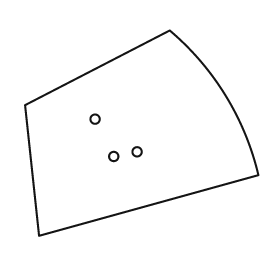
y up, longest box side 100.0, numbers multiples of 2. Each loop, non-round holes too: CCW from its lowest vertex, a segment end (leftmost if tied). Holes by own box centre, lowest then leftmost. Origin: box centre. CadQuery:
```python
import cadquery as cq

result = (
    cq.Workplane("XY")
    .moveTo(-44.0, -44.0)
    .lineTo(50.0, -18.0)
    .threePointArc((36.0, 16.0), (12.0, 44.0))
    .lineTo(-50.0, 12.0)
    .close()
    .moveTo(-12.0, -10.0)
    .circle(2.0)
    .moveTo(-2.0, -8.0)
    .circle(2.0)
    .moveTo(-20.0, 6.0)
    .circle(2.0)
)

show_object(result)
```